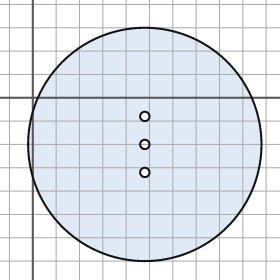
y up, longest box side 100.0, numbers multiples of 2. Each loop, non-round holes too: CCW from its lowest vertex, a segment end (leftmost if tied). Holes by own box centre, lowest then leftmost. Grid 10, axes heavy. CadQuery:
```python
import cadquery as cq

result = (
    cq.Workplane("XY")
    .moveTo(48.0, -20.0)
    .circle(50.0)
    .moveTo(48.0, -32.0)
    .circle(2.0)
    .moveTo(48.0, -20.0)
    .circle(2.0)
    .moveTo(48.0, -8.0)
    .circle(2.0)
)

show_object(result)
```